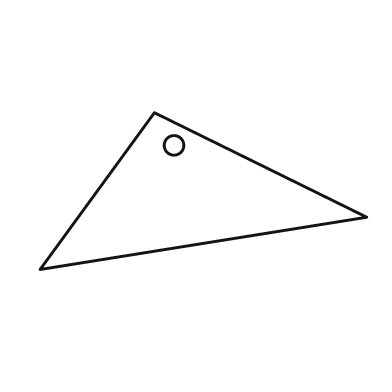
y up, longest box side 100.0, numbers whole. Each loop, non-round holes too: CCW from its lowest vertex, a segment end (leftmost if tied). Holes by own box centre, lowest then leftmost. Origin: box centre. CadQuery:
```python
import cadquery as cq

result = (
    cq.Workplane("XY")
    .moveTo(-50.0, -24.0)
    .lineTo(50.0, -8.0)
    .lineTo(-15.0, 24.0)
    .close()
    .moveTo(-9.0, 14.0)
    .circle(3.0)
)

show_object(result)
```